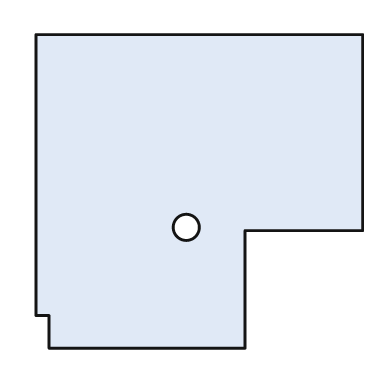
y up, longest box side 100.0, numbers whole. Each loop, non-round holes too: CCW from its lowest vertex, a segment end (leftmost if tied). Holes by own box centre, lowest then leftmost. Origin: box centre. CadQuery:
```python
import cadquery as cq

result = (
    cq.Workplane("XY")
    .moveTo(-46.0, -48.0)
    .lineTo(14.0, -48.0)
    .lineTo(14.0, -12.0)
    .lineTo(50.0, -12.0)
    .lineTo(50.0, 48.0)
    .lineTo(-50.0, 48.0)
    .lineTo(-50.0, -38.0)
    .lineTo(-46.0, -38.0)
    .close()
    .moveTo(-4.0, -11.0)
    .circle(4.0)
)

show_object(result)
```